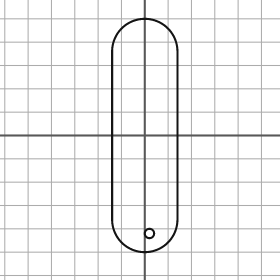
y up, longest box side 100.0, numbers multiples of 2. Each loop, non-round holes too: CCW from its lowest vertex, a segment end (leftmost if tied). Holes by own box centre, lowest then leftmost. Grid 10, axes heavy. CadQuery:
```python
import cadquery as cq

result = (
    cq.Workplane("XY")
    .moveTo(-14.0, -36.0)
    .threePointArc((0.0, -50.0), (14.0, -36.0))
    .lineTo(14.0, 36.0)
    .threePointArc((0.0, 50.0), (-14.0, 36.0))
    .close()
    .moveTo(2.0, -42.0)
    .circle(2.0)
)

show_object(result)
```